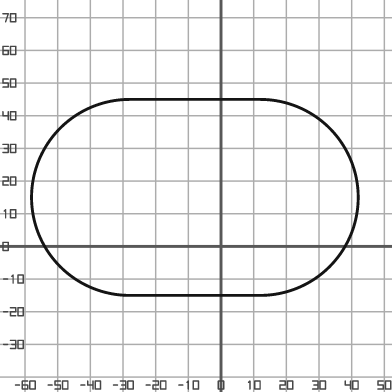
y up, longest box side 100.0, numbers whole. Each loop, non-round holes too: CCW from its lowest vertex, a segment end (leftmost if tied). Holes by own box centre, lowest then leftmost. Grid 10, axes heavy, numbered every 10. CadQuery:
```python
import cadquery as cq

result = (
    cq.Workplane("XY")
    .moveTo(-28.0, -15.0)
    .lineTo(12.0, -15.0)
    .threePointArc((42.0, 15.0), (12.0, 45.0))
    .lineTo(-28.0, 45.0)
    .threePointArc((-58.0, 15.0), (-28.0, -15.0))
    .close()
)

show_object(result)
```